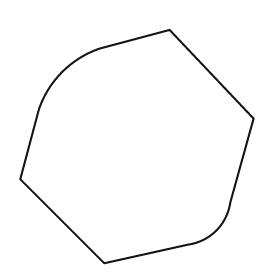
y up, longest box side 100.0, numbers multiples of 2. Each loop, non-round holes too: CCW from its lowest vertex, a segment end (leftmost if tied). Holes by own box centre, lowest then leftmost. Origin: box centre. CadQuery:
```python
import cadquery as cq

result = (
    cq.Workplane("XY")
    .moveTo(-14.0, -50.0)
    .lineTo(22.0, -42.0)
    .threePointArc((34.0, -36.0), (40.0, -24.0))
    .lineTo(50.0, 12.0)
    .lineTo(14.0, 50.0)
    .lineTo(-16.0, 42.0)
    .threePointArc((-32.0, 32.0), (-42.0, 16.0))
    .lineTo(-50.0, -14.0)
    .close()
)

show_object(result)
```